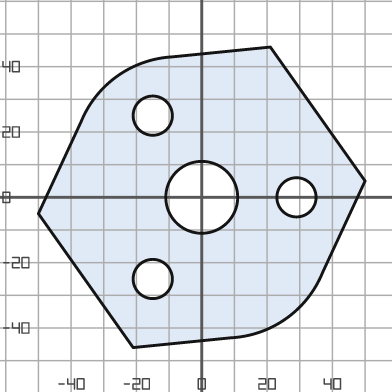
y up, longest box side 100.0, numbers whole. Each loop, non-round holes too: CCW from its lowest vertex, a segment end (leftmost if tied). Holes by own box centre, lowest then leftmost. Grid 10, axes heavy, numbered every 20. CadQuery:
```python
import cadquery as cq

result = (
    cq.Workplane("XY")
    .moveTo(-21.0, -46.0)
    .lineTo(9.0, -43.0)
    .threePointArc((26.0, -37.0), (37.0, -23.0))
    .lineTo(50.0, 5.0)
    .lineTo(21.0, 46.0)
    .lineTo(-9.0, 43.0)
    .threePointArc((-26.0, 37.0), (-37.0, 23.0))
    .lineTo(-50.0, -5.0)
    .close()
    .moveTo(-15.0, -25.0)
    .circle(6.0)
    .moveTo(0.0, 0.0)
    .circle(11.0)
    .moveTo(29.0, 0.0)
    .circle(6.0)
    .moveTo(-15.0, 25.0)
    .circle(6.0)
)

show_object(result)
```